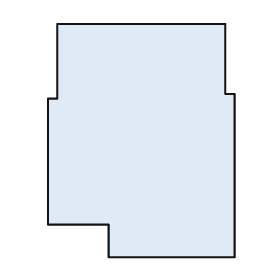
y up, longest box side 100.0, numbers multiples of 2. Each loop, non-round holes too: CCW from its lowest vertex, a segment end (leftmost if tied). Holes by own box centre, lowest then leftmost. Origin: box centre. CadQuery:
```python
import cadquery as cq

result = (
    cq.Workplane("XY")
    .moveTo(-14.0, -50.0)
    .lineTo(40.0, -50.0)
    .lineTo(40.0, 20.0)
    .lineTo(36.0, 20.0)
    .lineTo(36.0, 50.0)
    .lineTo(-36.0, 50.0)
    .lineTo(-36.0, 18.0)
    .lineTo(-40.0, 18.0)
    .lineTo(-40.0, -36.0)
    .lineTo(-14.0, -36.0)
    .close()
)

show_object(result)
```